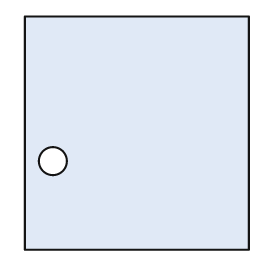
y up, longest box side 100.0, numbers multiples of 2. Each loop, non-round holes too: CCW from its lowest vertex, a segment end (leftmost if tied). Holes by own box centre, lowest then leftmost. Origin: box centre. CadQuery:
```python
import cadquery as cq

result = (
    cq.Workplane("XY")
    .moveTo(-48.0, -50.0)
    .lineTo(48.0, -50.0)
    .lineTo(48.0, 50.0)
    .lineTo(-48.0, 50.0)
    .close()
    .moveTo(-36.0, -12.0)
    .circle(6.0)
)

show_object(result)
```